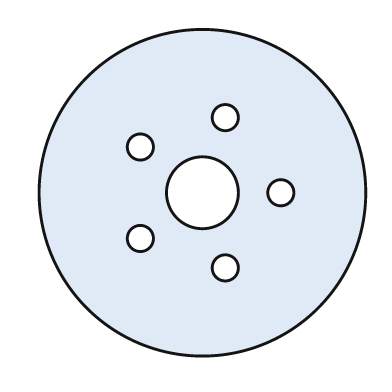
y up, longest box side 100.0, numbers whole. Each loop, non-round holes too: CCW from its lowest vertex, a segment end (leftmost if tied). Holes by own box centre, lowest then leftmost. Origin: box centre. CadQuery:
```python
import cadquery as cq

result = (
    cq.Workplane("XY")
    .moveTo(0.0, 0.0)
    .circle(50.0)
    .moveTo(7.0, -23.0)
    .circle(4.0)
    .moveTo(-19.0, -14.0)
    .circle(4.0)
    .moveTo(0.0, 0.0)
    .circle(11.0)
    .moveTo(24.0, 0.0)
    .circle(4.0)
    .moveTo(-19.0, 14.0)
    .circle(4.0)
    .moveTo(7.0, 23.0)
    .circle(4.0)
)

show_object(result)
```